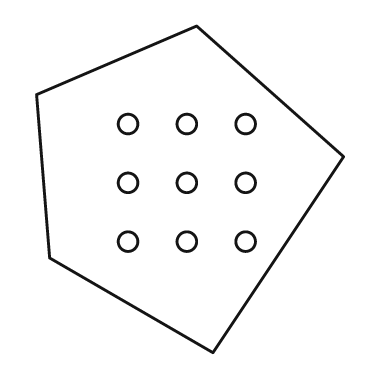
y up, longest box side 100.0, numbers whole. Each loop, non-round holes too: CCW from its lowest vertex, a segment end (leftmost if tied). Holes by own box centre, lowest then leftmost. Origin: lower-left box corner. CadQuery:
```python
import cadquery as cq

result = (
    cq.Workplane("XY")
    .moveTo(54.0, 0.0)
    .lineTo(94.0, 60.0)
    .lineTo(49.0, 100.0)
    .lineTo(0.0, 79.0)
    .lineTo(4.0, 29.0)
    .close()
    .moveTo(28.0, 34.0)
    .circle(3.0)
    .moveTo(46.0, 34.0)
    .circle(3.0)
    .moveTo(64.0, 34.0)
    .circle(3.0)
    .moveTo(28.0, 52.0)
    .circle(3.0)
    .moveTo(46.0, 52.0)
    .circle(3.0)
    .moveTo(64.0, 52.0)
    .circle(3.0)
    .moveTo(28.0, 70.0)
    .circle(3.0)
    .moveTo(46.0, 70.0)
    .circle(3.0)
    .moveTo(64.0, 70.0)
    .circle(3.0)
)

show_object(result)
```